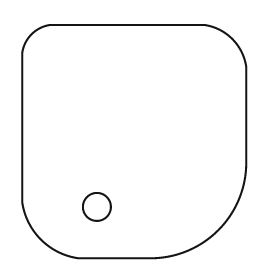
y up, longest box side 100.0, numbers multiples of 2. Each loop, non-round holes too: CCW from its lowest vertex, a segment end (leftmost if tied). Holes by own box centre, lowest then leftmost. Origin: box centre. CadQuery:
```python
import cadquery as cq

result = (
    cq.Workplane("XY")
    .moveTo(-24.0, -50.0)
    .lineTo(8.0, -50.0)
    .threePointArc((36.0, -38.0), (48.0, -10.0))
    .lineTo(48.0, 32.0)
    .threePointArc((42.0, 44.0), (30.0, 50.0))
    .lineTo(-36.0, 50.0)
    .threePointArc((-44.0, 46.0), (-48.0, 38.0))
    .lineTo(-48.0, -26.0)
    .threePointArc((-40.0, -42.0), (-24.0, -50.0))
    .close()
    .moveTo(-16.0, -28.0)
    .circle(6.0)
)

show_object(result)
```